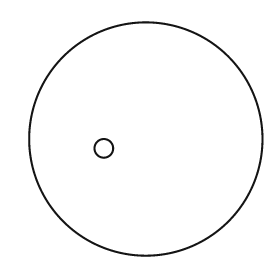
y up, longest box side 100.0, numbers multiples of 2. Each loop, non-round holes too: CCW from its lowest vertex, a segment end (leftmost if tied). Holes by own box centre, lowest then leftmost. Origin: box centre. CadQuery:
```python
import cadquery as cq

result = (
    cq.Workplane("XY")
    .moveTo(0.0, 0.0)
    .circle(50.0)
    .moveTo(-18.0, -4.0)
    .circle(4.0)
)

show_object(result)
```